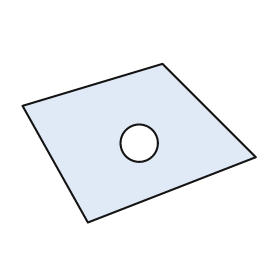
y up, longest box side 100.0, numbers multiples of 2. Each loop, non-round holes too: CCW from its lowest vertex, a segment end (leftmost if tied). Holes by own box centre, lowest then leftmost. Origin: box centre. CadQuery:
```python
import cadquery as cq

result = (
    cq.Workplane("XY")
    .moveTo(-22.0, -34.0)
    .lineTo(50.0, -6.0)
    .lineTo(10.0, 34.0)
    .lineTo(-50.0, 16.0)
    .close()
    .moveTo(0.0, 0.0)
    .circle(8.0)
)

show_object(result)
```